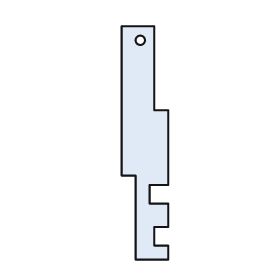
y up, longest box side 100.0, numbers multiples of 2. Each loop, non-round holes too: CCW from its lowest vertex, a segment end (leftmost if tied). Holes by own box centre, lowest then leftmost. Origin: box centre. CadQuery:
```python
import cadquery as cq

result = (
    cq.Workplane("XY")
    .moveTo(-4.0, -50.0)
    .lineTo(10.0, -50.0)
    .lineTo(10.0, -44.0)
    .lineTo(4.0, -44.0)
    .lineTo(4.0, -36.0)
    .lineTo(10.0, -36.0)
    .lineTo(10.0, -26.0)
    .lineTo(2.0, -26.0)
    .lineTo(2.0, -18.0)
    .lineTo(10.0, -18.0)
    .lineTo(10.0, 14.0)
    .lineTo(4.0, 14.0)
    .lineTo(4.0, 50.0)
    .lineTo(-10.0, 50.0)
    .lineTo(-10.0, -14.0)
    .lineTo(-4.0, -14.0)
    .close()
    .moveTo(-2.0, 44.0)
    .circle(2.0)
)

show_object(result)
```